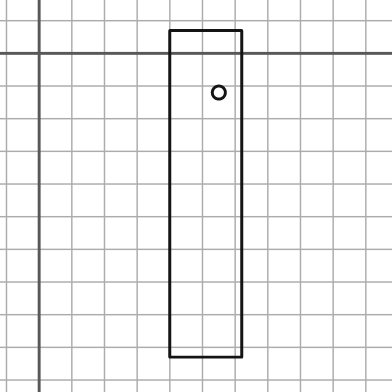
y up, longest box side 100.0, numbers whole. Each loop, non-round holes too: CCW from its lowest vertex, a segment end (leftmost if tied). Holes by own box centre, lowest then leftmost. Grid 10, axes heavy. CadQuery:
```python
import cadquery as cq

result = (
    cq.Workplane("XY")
    .moveTo(40.0, -93.0)
    .lineTo(62.0, -93.0)
    .lineTo(62.0, 7.0)
    .lineTo(40.0, 7.0)
    .close()
    .moveTo(55.0, -12.0)
    .circle(2.0)
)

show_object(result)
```